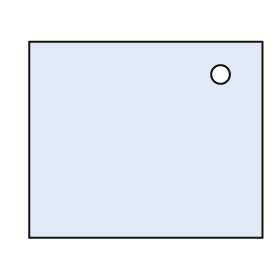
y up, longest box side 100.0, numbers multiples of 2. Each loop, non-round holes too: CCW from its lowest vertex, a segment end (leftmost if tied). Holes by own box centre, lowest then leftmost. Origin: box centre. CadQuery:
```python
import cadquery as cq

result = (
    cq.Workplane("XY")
    .moveTo(-50.0, -42.0)
    .lineTo(50.0, -42.0)
    .lineTo(50.0, 42.0)
    .lineTo(-50.0, 42.0)
    .close()
    .moveTo(32.0, 28.0)
    .circle(4.0)
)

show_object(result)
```